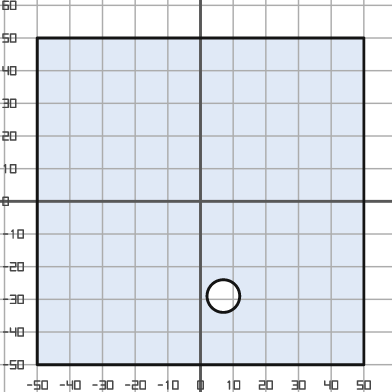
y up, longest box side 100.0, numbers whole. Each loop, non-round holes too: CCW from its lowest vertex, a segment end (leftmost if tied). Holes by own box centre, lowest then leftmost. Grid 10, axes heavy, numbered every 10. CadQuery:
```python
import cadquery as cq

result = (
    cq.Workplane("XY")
    .moveTo(-50.0, -50.0)
    .lineTo(50.0, -50.0)
    .lineTo(50.0, 50.0)
    .lineTo(-50.0, 50.0)
    .close()
    .moveTo(7.0, -29.0)
    .circle(5.0)
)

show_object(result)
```